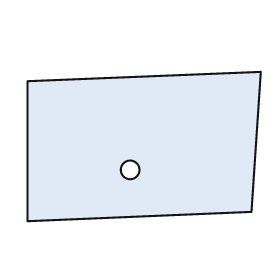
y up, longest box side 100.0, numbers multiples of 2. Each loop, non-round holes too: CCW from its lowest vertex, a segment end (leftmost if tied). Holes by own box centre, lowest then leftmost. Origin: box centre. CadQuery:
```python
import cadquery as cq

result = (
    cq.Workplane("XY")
    .moveTo(-50.0, -32.0)
    .lineTo(46.0, -28.0)
    .lineTo(50.0, 32.0)
    .lineTo(-50.0, 28.0)
    .close()
    .moveTo(-6.0, -10.0)
    .circle(4.0)
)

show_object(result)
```